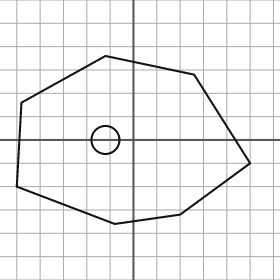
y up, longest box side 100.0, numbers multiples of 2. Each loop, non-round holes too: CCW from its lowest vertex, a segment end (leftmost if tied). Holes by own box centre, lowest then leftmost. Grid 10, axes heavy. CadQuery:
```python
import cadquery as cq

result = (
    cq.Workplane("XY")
    .moveTo(-8.0, -36.0)
    .lineTo(20.0, -32.0)
    .lineTo(50.0, -10.0)
    .lineTo(26.0, 28.0)
    .lineTo(-12.0, 36.0)
    .lineTo(-48.0, 16.0)
    .lineTo(-50.0, -20.0)
    .close()
    .moveTo(-12.0, 0.0)
    .circle(6.0)
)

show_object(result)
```